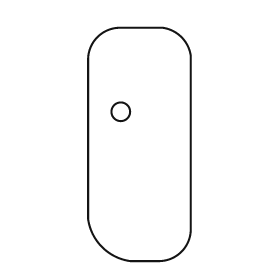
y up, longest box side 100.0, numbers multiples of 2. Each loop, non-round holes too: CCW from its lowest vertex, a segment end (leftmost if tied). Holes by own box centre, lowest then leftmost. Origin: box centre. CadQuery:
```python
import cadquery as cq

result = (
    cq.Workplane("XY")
    .moveTo(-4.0, -50.0)
    .lineTo(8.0, -50.0)
    .threePointArc((18.0, -46.0), (22.0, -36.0))
    .lineTo(22.0, 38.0)
    .threePointArc((18.0, 46.0), (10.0, 50.0))
    .lineTo(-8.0, 50.0)
    .threePointArc((-18.0, 46.0), (-22.0, 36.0))
    .lineTo(-22.0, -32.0)
    .threePointArc((-16.0, -44.0), (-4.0, -50.0))
    .close()
    .moveTo(-8.0, 14.0)
    .circle(4.0)
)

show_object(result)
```